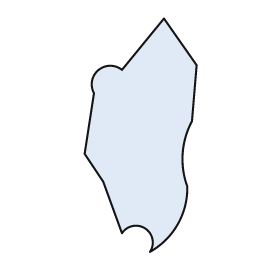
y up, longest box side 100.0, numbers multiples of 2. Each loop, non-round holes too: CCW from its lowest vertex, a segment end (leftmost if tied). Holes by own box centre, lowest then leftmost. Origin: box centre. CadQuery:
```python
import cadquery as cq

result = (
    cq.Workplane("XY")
    .moveTo(4.0, -50.0)
    .threePointArc((16.0, -38.0), (20.0, -22.0))
    .threePointArc((18.0, -8.0), (22.0, 6.0))
    .lineTo(24.0, 30.0)
    .lineTo(10.0, 50.0)
    .lineTo(-8.0, 28.0)
    .threePointArc((-18.0, 28.0), (-20.0, 18.0))
    .lineTo(-24.0, -8.0)
    .lineTo(-16.0, -20.0)
    .lineTo(-8.0, -42.0)
    .threePointArc((2.0, -40.0), (4.0, -50.0))
    .close()
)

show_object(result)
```